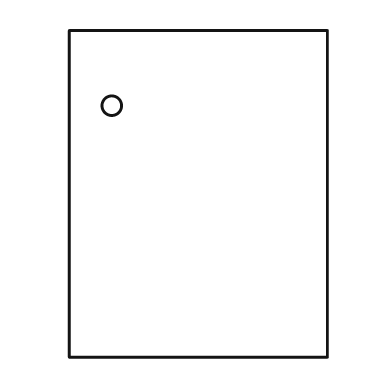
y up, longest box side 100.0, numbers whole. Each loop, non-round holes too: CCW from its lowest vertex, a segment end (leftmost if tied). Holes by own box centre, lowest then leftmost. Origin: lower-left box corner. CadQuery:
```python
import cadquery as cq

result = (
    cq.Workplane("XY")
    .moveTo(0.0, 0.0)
    .lineTo(79.0, 0.0)
    .lineTo(79.0, 100.0)
    .lineTo(0.0, 100.0)
    .close()
    .moveTo(13.0, 77.0)
    .circle(3.0)
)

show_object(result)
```